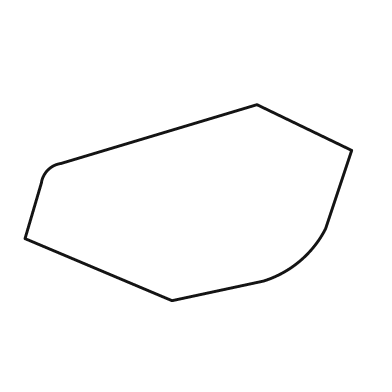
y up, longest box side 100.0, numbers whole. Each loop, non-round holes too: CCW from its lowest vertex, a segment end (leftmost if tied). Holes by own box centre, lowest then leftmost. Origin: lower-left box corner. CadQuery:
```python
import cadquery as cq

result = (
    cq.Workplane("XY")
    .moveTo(45.0, 0.0)
    .lineTo(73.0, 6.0)
    .threePointArc((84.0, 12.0), (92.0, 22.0))
    .lineTo(100.0, 46.0)
    .lineTo(71.0, 60.0)
    .lineTo(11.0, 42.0)
    .threePointArc((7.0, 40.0), (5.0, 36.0))
    .lineTo(0.0, 19.0)
    .close()
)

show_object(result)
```